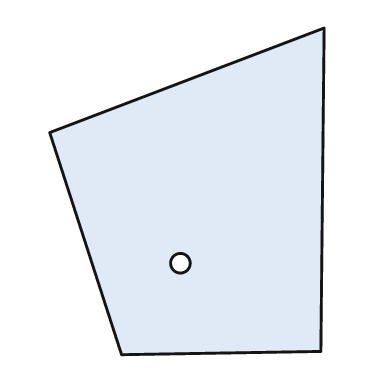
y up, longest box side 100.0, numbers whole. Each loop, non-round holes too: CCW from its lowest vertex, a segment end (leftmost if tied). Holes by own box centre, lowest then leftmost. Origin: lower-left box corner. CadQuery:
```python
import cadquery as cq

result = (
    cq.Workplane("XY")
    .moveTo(22.0, 0.0)
    .lineTo(83.0, 1.0)
    .lineTo(84.0, 100.0)
    .lineTo(0.0, 68.0)
    .close()
    .moveTo(40.0, 28.0)
    .circle(3.0)
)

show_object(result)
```